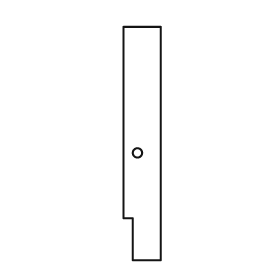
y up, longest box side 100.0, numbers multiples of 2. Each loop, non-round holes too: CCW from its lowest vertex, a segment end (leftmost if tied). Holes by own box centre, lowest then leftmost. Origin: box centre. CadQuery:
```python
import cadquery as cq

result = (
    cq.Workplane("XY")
    .moveTo(-4.0, -50.0)
    .lineTo(8.0, -50.0)
    .lineTo(8.0, 50.0)
    .lineTo(-8.0, 50.0)
    .lineTo(-8.0, -32.0)
    .lineTo(-4.0, -32.0)
    .close()
    .moveTo(-2.0, -4.0)
    .circle(2.0)
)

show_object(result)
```